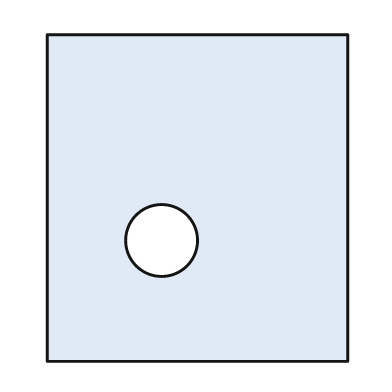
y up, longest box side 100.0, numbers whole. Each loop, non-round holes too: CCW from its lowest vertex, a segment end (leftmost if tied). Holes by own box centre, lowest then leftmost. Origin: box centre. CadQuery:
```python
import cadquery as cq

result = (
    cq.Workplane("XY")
    .moveTo(-46.0, -50.0)
    .lineTo(46.0, -50.0)
    .lineTo(46.0, 50.0)
    .lineTo(-46.0, 50.0)
    .close()
    .moveTo(-11.0, -13.0)
    .circle(11.0)
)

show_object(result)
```